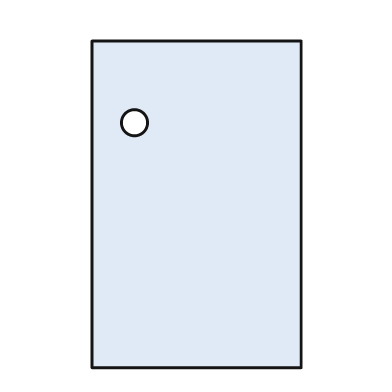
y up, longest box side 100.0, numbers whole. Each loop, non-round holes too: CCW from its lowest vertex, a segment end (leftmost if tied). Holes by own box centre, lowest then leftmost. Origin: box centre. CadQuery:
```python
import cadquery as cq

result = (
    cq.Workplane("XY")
    .moveTo(-32.0, -50.0)
    .lineTo(32.0, -50.0)
    .lineTo(32.0, 50.0)
    .lineTo(-32.0, 50.0)
    .close()
    .moveTo(-19.0, 25.0)
    .circle(4.0)
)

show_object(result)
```